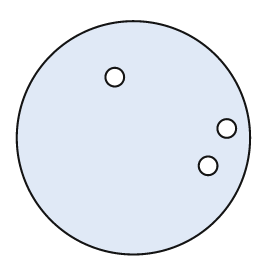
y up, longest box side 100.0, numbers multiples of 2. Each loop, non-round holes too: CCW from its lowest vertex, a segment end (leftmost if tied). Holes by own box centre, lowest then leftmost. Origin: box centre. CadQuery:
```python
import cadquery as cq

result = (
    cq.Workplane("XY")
    .moveTo(0.0, 0.0)
    .circle(50.0)
    .moveTo(32.0, -12.0)
    .circle(4.0)
    .moveTo(40.0, 4.0)
    .circle(4.0)
    .moveTo(-8.0, 26.0)
    .circle(4.0)
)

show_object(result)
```